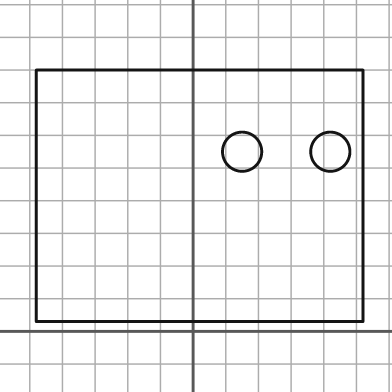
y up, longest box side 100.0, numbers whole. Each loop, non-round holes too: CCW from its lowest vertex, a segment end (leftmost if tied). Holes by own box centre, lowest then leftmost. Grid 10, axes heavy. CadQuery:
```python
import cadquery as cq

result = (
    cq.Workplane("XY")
    .moveTo(-48.0, 3.0)
    .lineTo(52.0, 3.0)
    .lineTo(52.0, 80.0)
    .lineTo(-48.0, 80.0)
    .close()
    .moveTo(15.0, 55.0)
    .circle(6.0)
    .moveTo(42.0, 55.0)
    .circle(6.0)
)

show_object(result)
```